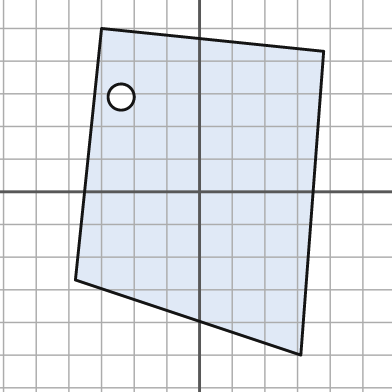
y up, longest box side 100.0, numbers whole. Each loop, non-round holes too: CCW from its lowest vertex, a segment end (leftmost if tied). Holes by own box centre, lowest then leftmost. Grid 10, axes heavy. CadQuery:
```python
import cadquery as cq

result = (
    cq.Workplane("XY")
    .moveTo(31.0, -50.0)
    .lineTo(38.0, 43.0)
    .lineTo(-30.0, 50.0)
    .lineTo(-38.0, -27.0)
    .close()
    .moveTo(-24.0, 29.0)
    .circle(4.0)
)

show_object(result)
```